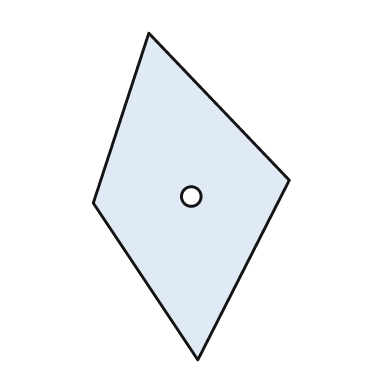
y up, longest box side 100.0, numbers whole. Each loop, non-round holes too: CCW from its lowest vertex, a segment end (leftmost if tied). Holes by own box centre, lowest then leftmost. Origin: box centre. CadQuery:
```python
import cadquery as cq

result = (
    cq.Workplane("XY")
    .moveTo(2.0, -50.0)
    .lineTo(30.0, 5.0)
    .lineTo(-13.0, 50.0)
    .lineTo(-30.0, -2.0)
    .close()
    .moveTo(0.0, 0.0)
    .circle(3.0)
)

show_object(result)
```